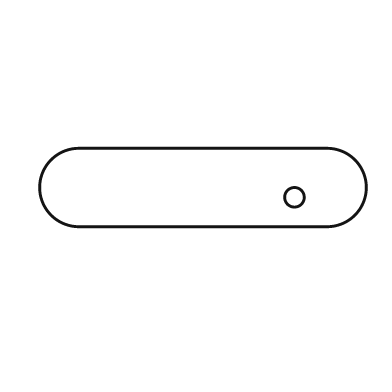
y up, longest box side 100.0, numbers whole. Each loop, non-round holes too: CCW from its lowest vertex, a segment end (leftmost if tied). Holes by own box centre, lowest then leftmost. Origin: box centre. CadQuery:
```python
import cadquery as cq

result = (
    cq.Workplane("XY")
    .moveTo(-38.0, -12.0)
    .lineTo(38.0, -12.0)
    .threePointArc((50.0, 0.0), (38.0, 12.0))
    .lineTo(-38.0, 12.0)
    .threePointArc((-50.0, 0.0), (-38.0, -12.0))
    .close()
    .moveTo(28.0, -3.0)
    .circle(3.0)
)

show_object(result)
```